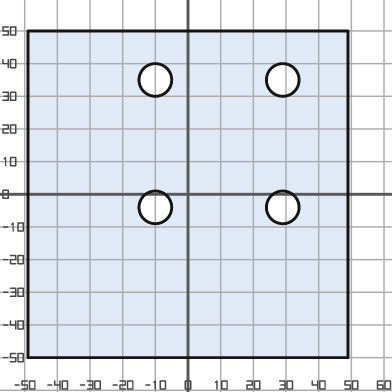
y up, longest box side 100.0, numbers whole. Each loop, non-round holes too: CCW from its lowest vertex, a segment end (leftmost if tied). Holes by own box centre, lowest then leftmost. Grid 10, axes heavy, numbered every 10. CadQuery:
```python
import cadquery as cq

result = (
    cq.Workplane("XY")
    .moveTo(-49.0, -50.0)
    .lineTo(49.0, -50.0)
    .lineTo(49.0, 50.0)
    .lineTo(-49.0, 50.0)
    .close()
    .moveTo(-10.0, -4.0)
    .circle(5.0)
    .moveTo(29.0, -4.0)
    .circle(5.0)
    .moveTo(-10.0, 35.0)
    .circle(5.0)
    .moveTo(29.0, 35.0)
    .circle(5.0)
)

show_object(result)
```